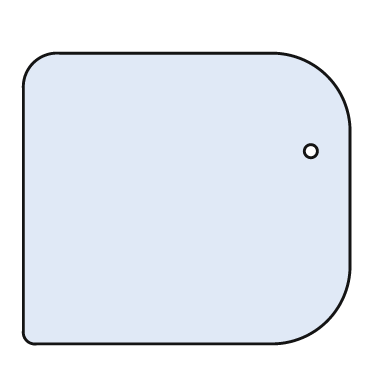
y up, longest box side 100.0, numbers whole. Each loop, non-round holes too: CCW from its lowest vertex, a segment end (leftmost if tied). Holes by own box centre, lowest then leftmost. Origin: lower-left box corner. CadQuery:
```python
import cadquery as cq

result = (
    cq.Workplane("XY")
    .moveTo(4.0, 0.0)
    .lineTo(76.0, 0.0)
    .threePointArc((93.0, 7.0), (100.0, 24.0))
    .lineTo(100.0, 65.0)
    .threePointArc((93.0, 82.0), (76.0, 89.0))
    .lineTo(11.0, 89.0)
    .threePointArc((3.0, 86.0), (0.0, 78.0))
    .lineTo(0.0, 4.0)
    .threePointArc((1.0, 1.0), (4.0, 0.0))
    .close()
    .moveTo(88.0, 59.0)
    .circle(2.0)
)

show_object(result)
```